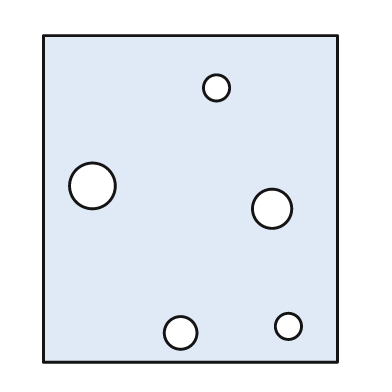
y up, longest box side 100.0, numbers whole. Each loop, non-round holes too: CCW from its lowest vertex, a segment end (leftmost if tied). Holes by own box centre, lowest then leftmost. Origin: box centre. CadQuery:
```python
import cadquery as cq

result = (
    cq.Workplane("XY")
    .moveTo(-45.0, -50.0)
    .lineTo(45.0, -50.0)
    .lineTo(45.0, 50.0)
    .lineTo(-45.0, 50.0)
    .close()
    .moveTo(-3.0, -41.0)
    .circle(5.0)
    .moveTo(30.0, -39.0)
    .circle(4.0)
    .moveTo(25.0, -3.0)
    .circle(6.0)
    .moveTo(-30.0, 4.0)
    .circle(7.0)
    .moveTo(8.0, 34.0)
    .circle(4.0)
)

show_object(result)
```